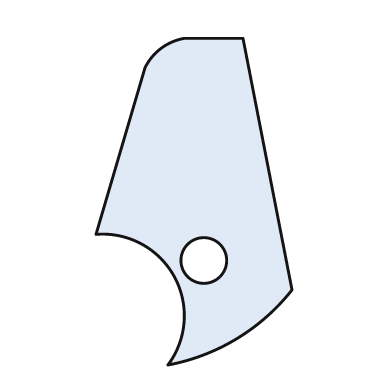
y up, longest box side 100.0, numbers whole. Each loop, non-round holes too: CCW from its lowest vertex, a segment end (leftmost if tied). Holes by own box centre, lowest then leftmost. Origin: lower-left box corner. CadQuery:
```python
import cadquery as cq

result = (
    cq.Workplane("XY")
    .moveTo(22.0, 0.0)
    .threePointArc((43.0, 8.0), (60.0, 23.0))
    .lineTo(45.0, 100.0)
    .lineTo(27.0, 100.0)
    .threePointArc((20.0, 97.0), (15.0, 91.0))
    .lineTo(0.0, 40.0)
    .threePointArc((24.0, 27.0), (22.0, 0.0))
    .close()
    .moveTo(33.0, 32.0)
    .circle(7.0)
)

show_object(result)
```